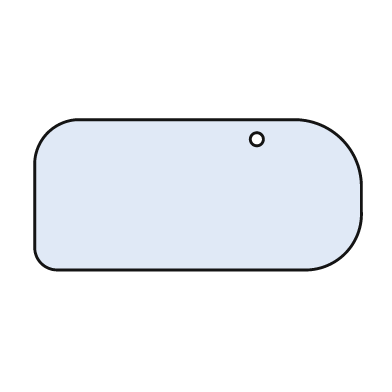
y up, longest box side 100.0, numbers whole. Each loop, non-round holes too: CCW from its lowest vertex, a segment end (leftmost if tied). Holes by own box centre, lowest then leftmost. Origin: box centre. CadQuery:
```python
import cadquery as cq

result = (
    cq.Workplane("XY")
    .moveTo(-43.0, -23.0)
    .lineTo(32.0, -23.0)
    .threePointArc((45.0, -18.0), (50.0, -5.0))
    .lineTo(50.0, 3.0)
    .threePointArc((44.0, 17.0), (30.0, 23.0))
    .lineTo(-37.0, 23.0)
    .threePointArc((-46.0, 19.0), (-50.0, 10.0))
    .lineTo(-50.0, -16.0)
    .threePointArc((-48.0, -21.0), (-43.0, -23.0))
    .close()
    .moveTo(18.0, 17.0)
    .circle(2.0)
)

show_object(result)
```